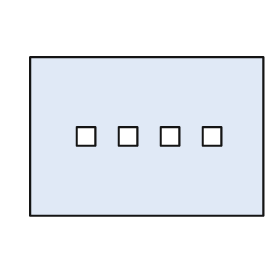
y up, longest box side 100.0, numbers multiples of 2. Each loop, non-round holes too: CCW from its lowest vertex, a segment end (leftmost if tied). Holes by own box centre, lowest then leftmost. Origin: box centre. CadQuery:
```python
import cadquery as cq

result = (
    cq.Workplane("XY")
    .moveTo(-50.0, -34.0)
    .lineTo(50.0, -34.0)
    .lineTo(50.0, 34.0)
    .lineTo(-50.0, 34.0)
    .close()
    .moveTo(-30.0, -4.0)
    .lineTo(-22.0, -4.0)
    .lineTo(-22.0, 4.0)
    .lineTo(-30.0, 4.0)
    .close()
    .moveTo(-12.0, -4.0)
    .lineTo(-4.0, -4.0)
    .lineTo(-4.0, 4.0)
    .lineTo(-12.0, 4.0)
    .close()
    .moveTo(6.0, -4.0)
    .lineTo(14.0, -4.0)
    .lineTo(14.0, 4.0)
    .lineTo(6.0, 4.0)
    .close()
    .moveTo(24.0, -4.0)
    .lineTo(32.0, -4.0)
    .lineTo(32.0, 4.0)
    .lineTo(24.0, 4.0)
    .close()
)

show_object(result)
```